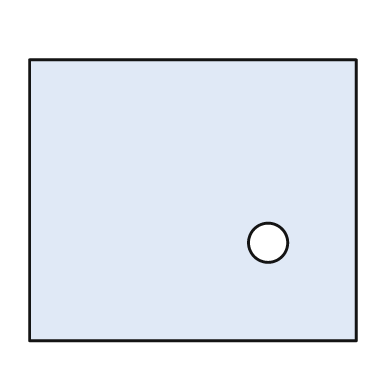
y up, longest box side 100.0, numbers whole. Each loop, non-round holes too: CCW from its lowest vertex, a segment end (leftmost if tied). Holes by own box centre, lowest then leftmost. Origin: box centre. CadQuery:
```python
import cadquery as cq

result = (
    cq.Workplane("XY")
    .moveTo(-50.0, -43.0)
    .lineTo(50.0, -43.0)
    .lineTo(50.0, 43.0)
    .lineTo(-50.0, 43.0)
    .close()
    .moveTo(23.0, -13.0)
    .circle(6.0)
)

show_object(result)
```